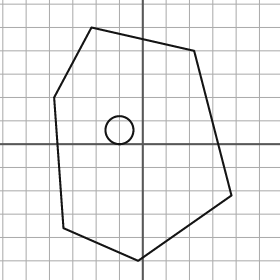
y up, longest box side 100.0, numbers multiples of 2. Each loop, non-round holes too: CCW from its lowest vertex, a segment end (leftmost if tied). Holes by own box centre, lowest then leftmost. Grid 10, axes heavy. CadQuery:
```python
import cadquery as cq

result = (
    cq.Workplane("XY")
    .moveTo(-2.0, -50.0)
    .lineTo(38.0, -22.0)
    .lineTo(22.0, 40.0)
    .lineTo(-22.0, 50.0)
    .lineTo(-38.0, 20.0)
    .lineTo(-34.0, -36.0)
    .close()
    .moveTo(-10.0, 6.0)
    .circle(6.0)
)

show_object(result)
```